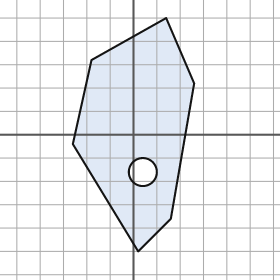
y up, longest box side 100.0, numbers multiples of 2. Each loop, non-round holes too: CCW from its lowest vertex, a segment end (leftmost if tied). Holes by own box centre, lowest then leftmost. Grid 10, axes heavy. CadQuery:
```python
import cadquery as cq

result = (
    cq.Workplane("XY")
    .moveTo(2.0, -50.0)
    .lineTo(16.0, -36.0)
    .lineTo(26.0, 22.0)
    .lineTo(14.0, 50.0)
    .lineTo(-18.0, 32.0)
    .lineTo(-26.0, -4.0)
    .close()
    .moveTo(4.0, -16.0)
    .circle(6.0)
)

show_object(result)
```